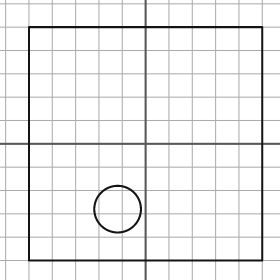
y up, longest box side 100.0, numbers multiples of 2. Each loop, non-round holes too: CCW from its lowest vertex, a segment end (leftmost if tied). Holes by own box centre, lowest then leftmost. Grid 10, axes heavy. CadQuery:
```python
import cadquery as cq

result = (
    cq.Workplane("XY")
    .moveTo(-50.0, -50.0)
    .lineTo(50.0, -50.0)
    .lineTo(50.0, 50.0)
    .lineTo(-50.0, 50.0)
    .close()
    .moveTo(-12.0, -28.0)
    .circle(10.0)
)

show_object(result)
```